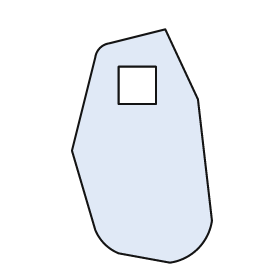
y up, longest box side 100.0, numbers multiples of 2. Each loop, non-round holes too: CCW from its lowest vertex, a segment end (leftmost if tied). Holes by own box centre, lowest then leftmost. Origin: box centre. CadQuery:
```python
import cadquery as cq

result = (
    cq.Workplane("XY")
    .moveTo(12.0, -50.0)
    .threePointArc((24.0, -44.0), (30.0, -32.0))
    .lineTo(24.0, 20.0)
    .lineTo(10.0, 50.0)
    .lineTo(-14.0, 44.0)
    .threePointArc((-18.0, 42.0), (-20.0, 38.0))
    .lineTo(-30.0, -2.0)
    .lineTo(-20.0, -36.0)
    .threePointArc((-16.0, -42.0), (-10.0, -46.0))
    .close()
    .moveTo(-10.0, 18.0)
    .lineTo(6.0, 18.0)
    .lineTo(6.0, 34.0)
    .lineTo(-10.0, 34.0)
    .close()
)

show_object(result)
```